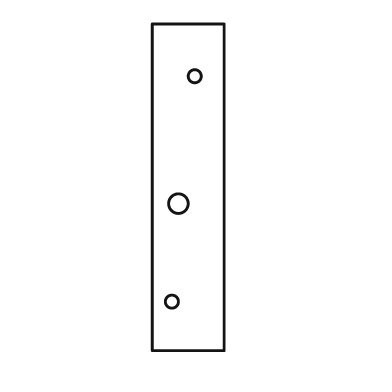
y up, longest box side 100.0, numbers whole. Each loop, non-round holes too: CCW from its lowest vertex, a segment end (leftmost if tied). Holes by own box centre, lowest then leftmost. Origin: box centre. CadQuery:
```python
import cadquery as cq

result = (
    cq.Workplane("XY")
    .moveTo(-11.0, -50.0)
    .lineTo(11.0, -50.0)
    .lineTo(11.0, 50.0)
    .lineTo(-11.0, 50.0)
    .close()
    .moveTo(-5.0, -35.0)
    .circle(2.0)
    .moveTo(-3.0, -5.0)
    .circle(3.0)
    .moveTo(2.0, 34.0)
    .circle(2.0)
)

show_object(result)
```